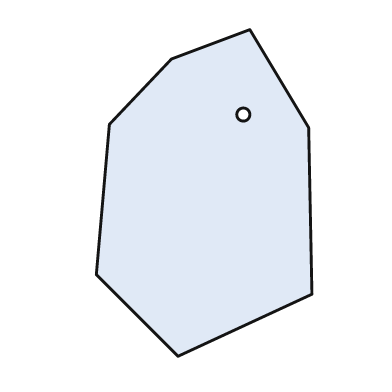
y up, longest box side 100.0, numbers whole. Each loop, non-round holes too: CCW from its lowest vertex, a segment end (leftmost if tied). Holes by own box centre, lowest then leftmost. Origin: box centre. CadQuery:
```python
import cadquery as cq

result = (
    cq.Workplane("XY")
    .moveTo(-8.0, -50.0)
    .lineTo(33.0, -31.0)
    .lineTo(32.0, 20.0)
    .lineTo(14.0, 50.0)
    .lineTo(-10.0, 41.0)
    .lineTo(-29.0, 21.0)
    .lineTo(-33.0, -25.0)
    .close()
    .moveTo(12.0, 24.0)
    .circle(2.0)
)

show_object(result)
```